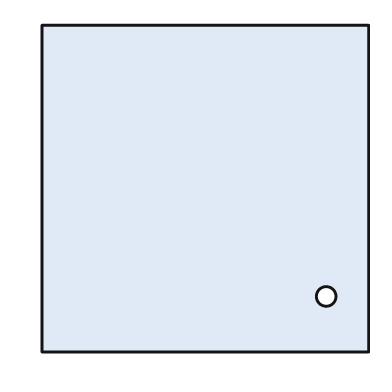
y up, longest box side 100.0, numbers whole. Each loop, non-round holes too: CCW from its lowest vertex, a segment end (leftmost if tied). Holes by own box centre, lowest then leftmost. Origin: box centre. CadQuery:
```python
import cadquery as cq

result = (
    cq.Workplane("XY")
    .moveTo(-50.0, -50.0)
    .lineTo(50.0, -50.0)
    .lineTo(50.0, 50.0)
    .lineTo(-50.0, 50.0)
    .close()
    .moveTo(37.0, -33.0)
    .circle(3.0)
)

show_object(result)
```